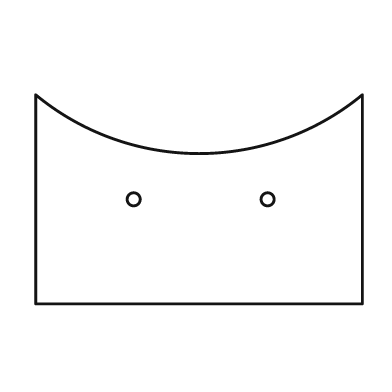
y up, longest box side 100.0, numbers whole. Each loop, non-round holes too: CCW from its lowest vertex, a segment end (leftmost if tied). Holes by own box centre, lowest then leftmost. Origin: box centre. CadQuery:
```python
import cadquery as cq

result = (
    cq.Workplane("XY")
    .moveTo(-50.0, -32.0)
    .lineTo(50.0, -32.0)
    .lineTo(50.0, 32.0)
    .threePointArc((0.0, 14.0), (-50.0, 32.0))
    .close()
    .moveTo(-20.0, 0.0)
    .circle(2.0)
    .moveTo(21.0, 0.0)
    .circle(2.0)
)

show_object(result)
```